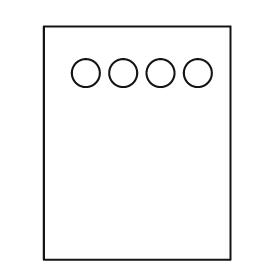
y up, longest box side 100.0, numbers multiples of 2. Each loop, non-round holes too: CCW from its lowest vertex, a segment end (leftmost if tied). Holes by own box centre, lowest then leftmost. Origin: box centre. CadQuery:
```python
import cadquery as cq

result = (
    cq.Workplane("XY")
    .moveTo(-40.0, -50.0)
    .lineTo(40.0, -50.0)
    .lineTo(40.0, 50.0)
    .lineTo(-40.0, 50.0)
    .close()
    .moveTo(-22.0, 30.0)
    .circle(6.0)
    .moveTo(-6.0, 30.0)
    .circle(6.0)
    .moveTo(10.0, 30.0)
    .circle(6.0)
    .moveTo(26.0, 30.0)
    .circle(6.0)
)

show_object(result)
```